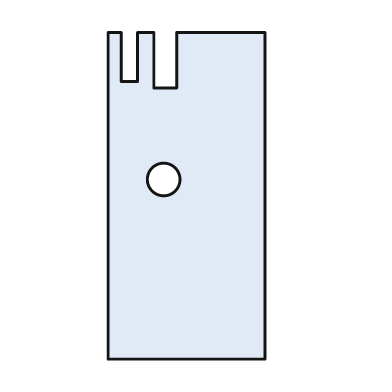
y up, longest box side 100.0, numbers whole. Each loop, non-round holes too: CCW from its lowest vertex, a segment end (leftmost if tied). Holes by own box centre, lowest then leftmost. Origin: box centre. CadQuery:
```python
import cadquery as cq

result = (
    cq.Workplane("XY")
    .moveTo(-24.0, -50.0)
    .lineTo(24.0, -50.0)
    .lineTo(24.0, 50.0)
    .lineTo(-3.0, 50.0)
    .lineTo(-3.0, 33.0)
    .lineTo(-10.0, 33.0)
    .lineTo(-10.0, 50.0)
    .lineTo(-15.0, 50.0)
    .lineTo(-15.0, 35.0)
    .lineTo(-20.0, 35.0)
    .lineTo(-20.0, 50.0)
    .lineTo(-24.0, 50.0)
    .close()
    .moveTo(-7.0, 5.0)
    .circle(5.0)
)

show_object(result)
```